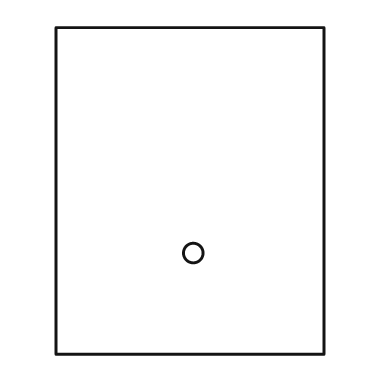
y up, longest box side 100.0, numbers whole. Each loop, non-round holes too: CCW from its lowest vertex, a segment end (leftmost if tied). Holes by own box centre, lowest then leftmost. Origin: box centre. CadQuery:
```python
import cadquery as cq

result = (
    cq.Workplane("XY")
    .moveTo(-41.0, -50.0)
    .lineTo(41.0, -50.0)
    .lineTo(41.0, 50.0)
    .lineTo(-41.0, 50.0)
    .close()
    .moveTo(1.0, -19.0)
    .circle(3.0)
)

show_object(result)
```